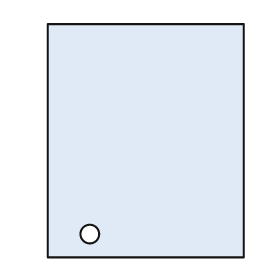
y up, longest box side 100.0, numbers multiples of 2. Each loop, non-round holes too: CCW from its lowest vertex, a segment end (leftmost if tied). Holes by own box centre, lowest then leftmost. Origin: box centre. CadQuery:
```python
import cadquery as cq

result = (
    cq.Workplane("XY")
    .moveTo(-42.0, -50.0)
    .lineTo(42.0, -50.0)
    .lineTo(42.0, 50.0)
    .lineTo(-42.0, 50.0)
    .close()
    .moveTo(-24.0, -40.0)
    .circle(4.0)
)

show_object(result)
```